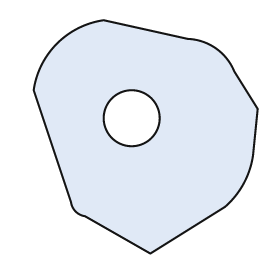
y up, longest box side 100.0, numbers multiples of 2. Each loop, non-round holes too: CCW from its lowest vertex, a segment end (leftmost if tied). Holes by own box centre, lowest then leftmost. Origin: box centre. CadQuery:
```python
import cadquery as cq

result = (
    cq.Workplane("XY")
    .moveTo(2.0, -50.0)
    .lineTo(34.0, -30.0)
    .threePointArc((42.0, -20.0), (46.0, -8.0))
    .lineTo(48.0, 12.0)
    .lineTo(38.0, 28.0)
    .threePointArc((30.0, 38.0), (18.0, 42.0))
    .lineTo(-18.0, 50.0)
    .threePointArc((-38.0, 40.0), (-48.0, 20.0))
    .lineTo(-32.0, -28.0)
    .threePointArc((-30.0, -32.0), (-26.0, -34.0))
    .close()
    .moveTo(-6.0, 8.0)
    .circle(12.0)
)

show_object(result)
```